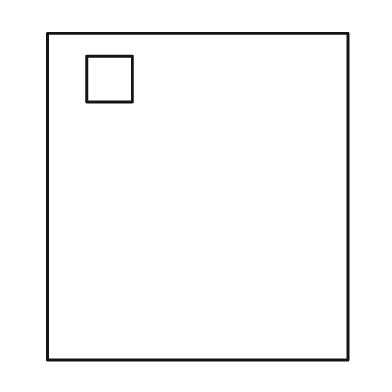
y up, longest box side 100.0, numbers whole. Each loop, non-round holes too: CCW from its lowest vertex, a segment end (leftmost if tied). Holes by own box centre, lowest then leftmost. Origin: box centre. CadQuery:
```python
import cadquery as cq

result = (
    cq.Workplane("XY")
    .moveTo(-46.0, -50.0)
    .lineTo(46.0, -50.0)
    .lineTo(46.0, 50.0)
    .lineTo(-46.0, 50.0)
    .close()
    .moveTo(-34.0, 29.0)
    .lineTo(-20.0, 29.0)
    .lineTo(-20.0, 43.0)
    .lineTo(-34.0, 43.0)
    .close()
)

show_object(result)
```